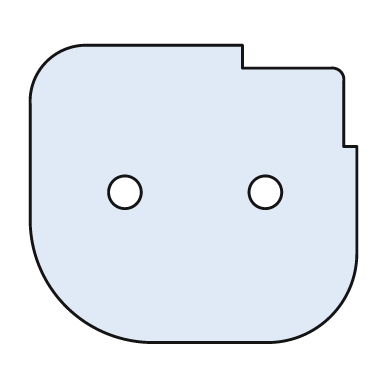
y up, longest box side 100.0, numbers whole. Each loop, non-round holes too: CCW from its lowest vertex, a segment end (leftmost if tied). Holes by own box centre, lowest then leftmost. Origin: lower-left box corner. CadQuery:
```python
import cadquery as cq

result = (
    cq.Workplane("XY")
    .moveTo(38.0, 0.0)
    .lineTo(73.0, 0.0)
    .threePointArc((92.0, 8.0), (100.0, 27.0))
    .lineTo(100.0, 60.0)
    .lineTo(96.0, 60.0)
    .lineTo(96.0, 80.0)
    .threePointArc((95.0, 83.0), (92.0, 84.0))
    .lineTo(65.0, 84.0)
    .lineTo(65.0, 91.0)
    .lineTo(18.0, 91.0)
    .threePointArc((5.0, 86.0), (0.0, 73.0))
    .lineTo(0.0, 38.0)
    .threePointArc((11.0, 11.0), (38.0, 0.0))
    .close()
    .moveTo(29.0, 46.0)
    .circle(5.0)
    .moveTo(72.0, 46.0)
    .circle(5.0)
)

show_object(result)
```